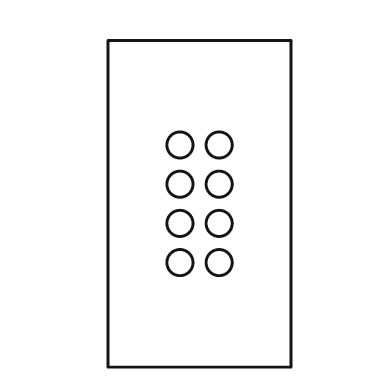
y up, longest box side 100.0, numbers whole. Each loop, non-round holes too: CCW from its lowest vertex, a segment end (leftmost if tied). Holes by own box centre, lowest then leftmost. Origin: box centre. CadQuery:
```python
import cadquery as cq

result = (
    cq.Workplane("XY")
    .moveTo(-28.0, -50.0)
    .lineTo(28.0, -50.0)
    .lineTo(28.0, 50.0)
    .lineTo(-28.0, 50.0)
    .close()
    .moveTo(-6.0, -18.0)
    .circle(4.0)
    .moveTo(6.0, -18.0)
    .circle(4.0)
    .moveTo(-6.0, -6.0)
    .circle(4.0)
    .moveTo(6.0, -6.0)
    .circle(4.0)
    .moveTo(-6.0, 6.0)
    .circle(4.0)
    .moveTo(6.0, 6.0)
    .circle(4.0)
    .moveTo(-6.0, 18.0)
    .circle(4.0)
    .moveTo(6.0, 18.0)
    .circle(4.0)
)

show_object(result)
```